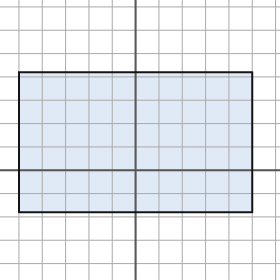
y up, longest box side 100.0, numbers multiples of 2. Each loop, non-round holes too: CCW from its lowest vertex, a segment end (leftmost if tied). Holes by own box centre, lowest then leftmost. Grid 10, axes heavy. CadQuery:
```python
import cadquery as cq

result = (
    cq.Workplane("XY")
    .moveTo(-50.0, -18.0)
    .lineTo(50.0, -18.0)
    .lineTo(50.0, 42.0)
    .lineTo(-50.0, 42.0)
    .close()
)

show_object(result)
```